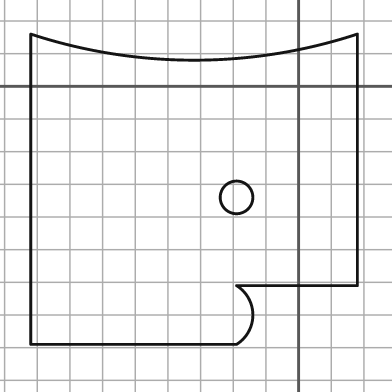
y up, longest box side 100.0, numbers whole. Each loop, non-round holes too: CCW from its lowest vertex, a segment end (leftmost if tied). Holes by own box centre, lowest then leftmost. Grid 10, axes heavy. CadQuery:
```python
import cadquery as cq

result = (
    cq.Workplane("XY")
    .moveTo(-82.0, -79.0)
    .lineTo(-19.0, -79.0)
    .threePointArc((-14.0, -70.0), (-19.0, -61.0))
    .lineTo(18.0, -61.0)
    .lineTo(18.0, 16.0)
    .threePointArc((-32.0, 8.0), (-82.0, 16.0))
    .close()
    .moveTo(-19.0, -34.0)
    .circle(5.0)
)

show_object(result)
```